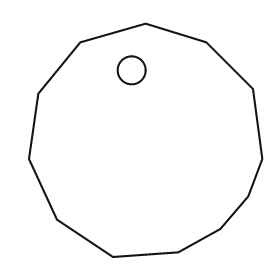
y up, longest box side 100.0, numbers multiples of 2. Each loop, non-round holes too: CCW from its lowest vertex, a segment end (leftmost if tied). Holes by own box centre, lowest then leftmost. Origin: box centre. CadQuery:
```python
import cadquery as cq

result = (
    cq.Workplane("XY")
    .moveTo(-14.0, -50.0)
    .lineTo(14.0, -48.0)
    .lineTo(32.0, -38.0)
    .lineTo(44.0, -24.0)
    .lineTo(50.0, -8.0)
    .lineTo(46.0, 22.0)
    .lineTo(26.0, 42.0)
    .lineTo(0.0, 50.0)
    .lineTo(-28.0, 42.0)
    .lineTo(-46.0, 20.0)
    .lineTo(-50.0, -8.0)
    .lineTo(-38.0, -34.0)
    .close()
    .moveTo(-6.0, 30.0)
    .circle(6.0)
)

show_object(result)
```